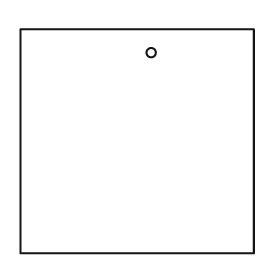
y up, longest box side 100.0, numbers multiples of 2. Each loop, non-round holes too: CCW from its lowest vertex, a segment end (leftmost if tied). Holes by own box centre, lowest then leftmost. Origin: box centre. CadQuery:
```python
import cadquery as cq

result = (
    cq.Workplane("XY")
    .moveTo(-50.0, -48.0)
    .lineTo(50.0, -48.0)
    .lineTo(50.0, 48.0)
    .lineTo(-50.0, 48.0)
    .close()
    .moveTo(6.0, 38.0)
    .circle(2.0)
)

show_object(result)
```